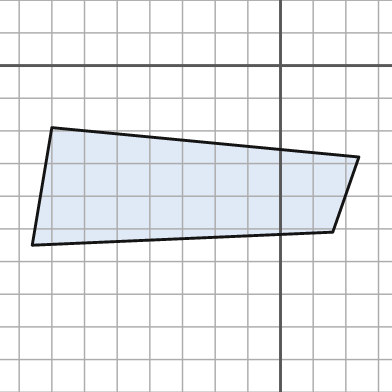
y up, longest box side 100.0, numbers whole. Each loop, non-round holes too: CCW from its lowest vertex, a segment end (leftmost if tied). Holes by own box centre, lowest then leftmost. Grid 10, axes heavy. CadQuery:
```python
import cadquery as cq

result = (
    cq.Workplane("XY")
    .moveTo(-76.0, -55.0)
    .lineTo(16.0, -51.0)
    .lineTo(24.0, -28.0)
    .lineTo(-70.0, -19.0)
    .close()
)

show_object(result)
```